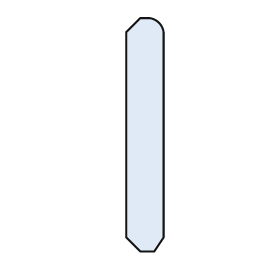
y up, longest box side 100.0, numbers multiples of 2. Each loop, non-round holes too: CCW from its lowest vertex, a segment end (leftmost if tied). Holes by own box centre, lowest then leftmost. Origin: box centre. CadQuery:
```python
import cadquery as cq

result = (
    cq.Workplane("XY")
    .moveTo(-2.0, -50.0)
    .lineTo(4.0, -50.0)
    .lineTo(8.0, -44.0)
    .lineTo(8.0, 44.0)
    .threePointArc((6.0, 48.0), (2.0, 50.0))
    .lineTo(-2.0, 50.0)
    .lineTo(-8.0, 44.0)
    .lineTo(-8.0, -44.0)
    .close()
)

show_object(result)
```